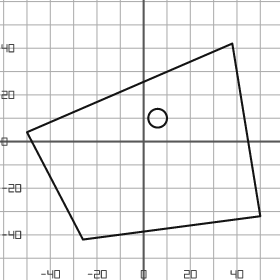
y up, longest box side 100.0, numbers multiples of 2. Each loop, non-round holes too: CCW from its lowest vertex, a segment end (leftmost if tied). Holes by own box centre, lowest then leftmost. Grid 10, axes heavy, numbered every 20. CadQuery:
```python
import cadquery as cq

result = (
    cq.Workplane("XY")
    .moveTo(-26.0, -42.0)
    .lineTo(50.0, -32.0)
    .lineTo(38.0, 42.0)
    .lineTo(-50.0, 4.0)
    .close()
    .moveTo(6.0, 10.0)
    .circle(4.0)
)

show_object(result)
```